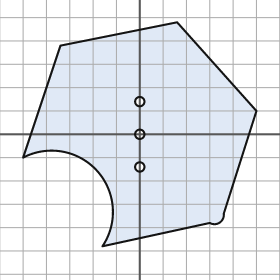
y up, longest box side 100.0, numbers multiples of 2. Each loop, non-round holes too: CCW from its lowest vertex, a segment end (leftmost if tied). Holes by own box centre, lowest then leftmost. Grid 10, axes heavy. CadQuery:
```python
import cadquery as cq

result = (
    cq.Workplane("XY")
    .moveTo(-16.0, -48.0)
    .lineTo(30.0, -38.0)
    .threePointArc((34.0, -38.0), (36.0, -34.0))
    .lineTo(50.0, 10.0)
    .lineTo(16.0, 48.0)
    .lineTo(-34.0, 38.0)
    .lineTo(-50.0, -10.0)
    .threePointArc((-18.0, -16.0), (-16.0, -48.0))
    .close()
    .moveTo(0.0, -14.0)
    .circle(2.0)
    .moveTo(0.0, 0.0)
    .circle(2.0)
    .moveTo(0.0, 14.0)
    .circle(2.0)
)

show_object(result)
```